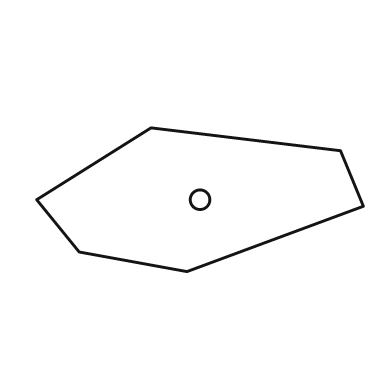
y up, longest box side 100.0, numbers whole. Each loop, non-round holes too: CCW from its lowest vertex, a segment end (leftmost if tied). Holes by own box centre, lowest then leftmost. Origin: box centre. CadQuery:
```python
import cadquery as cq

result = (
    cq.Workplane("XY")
    .moveTo(-4.0, -22.0)
    .lineTo(50.0, -2.0)
    .lineTo(43.0, 15.0)
    .lineTo(-15.0, 22.0)
    .lineTo(-50.0, 0.0)
    .lineTo(-37.0, -16.0)
    .close()
    .moveTo(0.0, 0.0)
    .circle(3.0)
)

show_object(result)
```